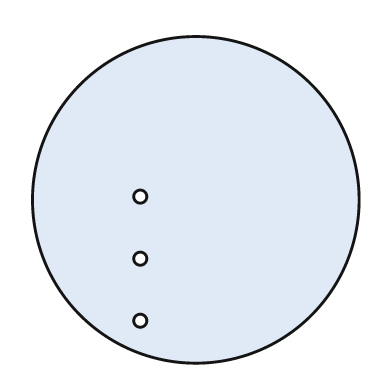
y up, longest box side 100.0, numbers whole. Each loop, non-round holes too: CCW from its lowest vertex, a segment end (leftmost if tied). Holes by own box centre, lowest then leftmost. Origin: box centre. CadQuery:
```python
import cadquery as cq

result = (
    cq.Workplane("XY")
    .moveTo(0.0, 0.0)
    .circle(50.0)
    .moveTo(-17.0, -37.0)
    .circle(2.0)
    .moveTo(-17.0, -18.0)
    .circle(2.0)
    .moveTo(-17.0, 1.0)
    .circle(2.0)
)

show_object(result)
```